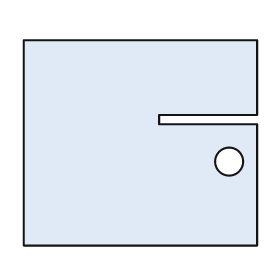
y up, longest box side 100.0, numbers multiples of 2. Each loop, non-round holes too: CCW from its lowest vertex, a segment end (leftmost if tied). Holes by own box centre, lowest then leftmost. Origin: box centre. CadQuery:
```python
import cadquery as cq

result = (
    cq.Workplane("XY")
    .moveTo(-50.0, -44.0)
    .lineTo(50.0, -44.0)
    .lineTo(50.0, 8.0)
    .lineTo(8.0, 8.0)
    .lineTo(8.0, 12.0)
    .lineTo(50.0, 12.0)
    .lineTo(50.0, 44.0)
    .lineTo(-50.0, 44.0)
    .close()
    .moveTo(38.0, -8.0)
    .circle(6.0)
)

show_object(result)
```